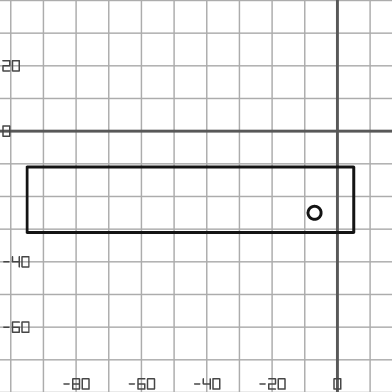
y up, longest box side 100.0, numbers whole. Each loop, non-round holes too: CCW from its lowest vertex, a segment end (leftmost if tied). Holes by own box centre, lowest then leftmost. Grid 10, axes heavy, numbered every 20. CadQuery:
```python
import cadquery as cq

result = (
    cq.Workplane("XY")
    .moveTo(-95.0, -31.0)
    .lineTo(5.0, -31.0)
    .lineTo(5.0, -11.0)
    .lineTo(-95.0, -11.0)
    .close()
    .moveTo(-7.0, -25.0)
    .circle(2.0)
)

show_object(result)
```